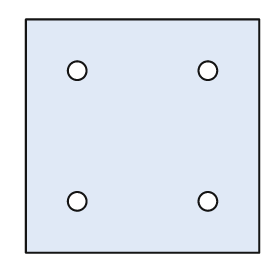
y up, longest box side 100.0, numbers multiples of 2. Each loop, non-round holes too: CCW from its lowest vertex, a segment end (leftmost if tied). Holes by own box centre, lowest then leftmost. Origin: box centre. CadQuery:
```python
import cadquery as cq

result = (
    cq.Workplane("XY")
    .moveTo(-50.0, -50.0)
    .lineTo(50.0, -50.0)
    .lineTo(50.0, 50.0)
    .lineTo(-50.0, 50.0)
    .close()
    .moveTo(-28.0, -28.0)
    .circle(4.0)
    .moveTo(28.0, -28.0)
    .circle(4.0)
    .moveTo(-28.0, 28.0)
    .circle(4.0)
    .moveTo(28.0, 28.0)
    .circle(4.0)
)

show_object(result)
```